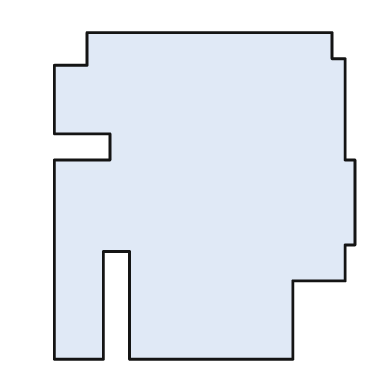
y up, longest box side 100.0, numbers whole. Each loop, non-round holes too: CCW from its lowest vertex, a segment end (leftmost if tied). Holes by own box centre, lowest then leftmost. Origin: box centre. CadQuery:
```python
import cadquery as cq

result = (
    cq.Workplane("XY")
    .moveTo(-46.0, -50.0)
    .lineTo(-31.0, -50.0)
    .lineTo(-31.0, -17.0)
    .lineTo(-23.0, -17.0)
    .lineTo(-23.0, -50.0)
    .lineTo(27.0, -50.0)
    .lineTo(27.0, -26.0)
    .lineTo(43.0, -26.0)
    .lineTo(43.0, -15.0)
    .lineTo(46.0, -15.0)
    .lineTo(46.0, 11.0)
    .lineTo(43.0, 11.0)
    .lineTo(43.0, 42.0)
    .lineTo(39.0, 42.0)
    .lineTo(39.0, 50.0)
    .lineTo(-36.0, 50.0)
    .lineTo(-36.0, 40.0)
    .lineTo(-46.0, 40.0)
    .lineTo(-46.0, 19.0)
    .lineTo(-29.0, 19.0)
    .lineTo(-29.0, 11.0)
    .lineTo(-46.0, 11.0)
    .close()
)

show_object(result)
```